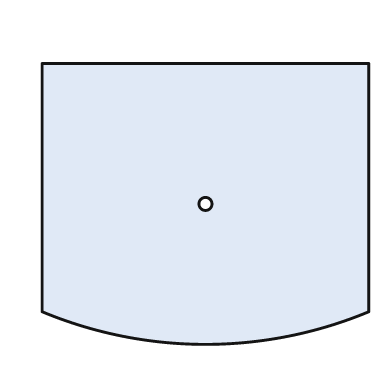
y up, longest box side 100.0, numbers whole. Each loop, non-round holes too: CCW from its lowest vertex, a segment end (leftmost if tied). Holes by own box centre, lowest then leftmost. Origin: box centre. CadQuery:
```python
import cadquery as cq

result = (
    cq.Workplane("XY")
    .moveTo(-50.0, -33.0)
    .threePointArc((0.0, -43.0), (50.0, -33.0))
    .lineTo(50.0, 43.0)
    .lineTo(-50.0, 43.0)
    .close()
    .moveTo(0.0, 0.0)
    .circle(2.0)
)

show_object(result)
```